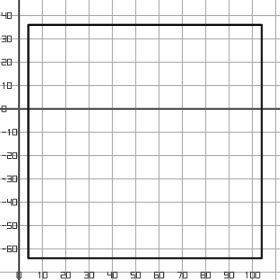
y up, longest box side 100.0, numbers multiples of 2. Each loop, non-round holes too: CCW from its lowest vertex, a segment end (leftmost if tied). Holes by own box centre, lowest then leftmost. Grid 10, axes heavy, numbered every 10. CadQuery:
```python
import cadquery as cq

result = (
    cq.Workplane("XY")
    .moveTo(4.0, -64.0)
    .lineTo(104.0, -64.0)
    .lineTo(104.0, 36.0)
    .lineTo(4.0, 36.0)
    .close()
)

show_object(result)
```